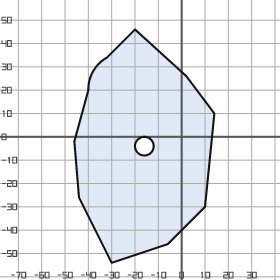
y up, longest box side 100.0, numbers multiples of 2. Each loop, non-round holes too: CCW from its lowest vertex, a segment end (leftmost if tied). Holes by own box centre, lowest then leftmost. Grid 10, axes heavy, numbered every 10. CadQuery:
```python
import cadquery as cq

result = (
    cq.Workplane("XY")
    .moveTo(-30.0, -54.0)
    .lineTo(-6.0, -46.0)
    .lineTo(10.0, -30.0)
    .lineTo(14.0, 10.0)
    .lineTo(2.0, 26.0)
    .lineTo(-20.0, 46.0)
    .lineTo(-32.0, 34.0)
    .threePointArc((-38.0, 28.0), (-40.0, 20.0))
    .lineTo(-46.0, -2.0)
    .lineTo(-44.0, -26.0)
    .close()
    .moveTo(-16.0, -4.0)
    .circle(4.0)
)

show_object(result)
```